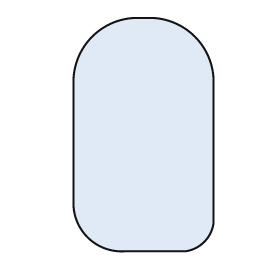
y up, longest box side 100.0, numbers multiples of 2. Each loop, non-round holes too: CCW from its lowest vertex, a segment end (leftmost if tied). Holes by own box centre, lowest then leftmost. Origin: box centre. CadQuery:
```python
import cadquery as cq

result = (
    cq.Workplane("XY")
    .moveTo(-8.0, -50.0)
    .lineTo(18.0, -50.0)
    .threePointArc((26.0, -46.0), (30.0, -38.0))
    .lineTo(30.0, 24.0)
    .threePointArc((22.0, 42.0), (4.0, 50.0))
    .lineTo(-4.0, 50.0)
    .threePointArc((-22.0, 42.0), (-30.0, 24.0))
    .lineTo(-30.0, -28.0)
    .threePointArc((-24.0, -44.0), (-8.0, -50.0))
    .close()
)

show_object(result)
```